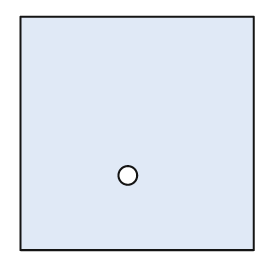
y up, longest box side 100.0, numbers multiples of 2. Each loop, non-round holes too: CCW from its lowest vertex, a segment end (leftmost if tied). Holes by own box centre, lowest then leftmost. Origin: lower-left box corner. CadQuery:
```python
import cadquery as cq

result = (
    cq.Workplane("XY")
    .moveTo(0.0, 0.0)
    .lineTo(100.0, 0.0)
    .lineTo(100.0, 100.0)
    .lineTo(0.0, 100.0)
    .close()
    .moveTo(46.0, 32.0)
    .circle(4.0)
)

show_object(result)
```